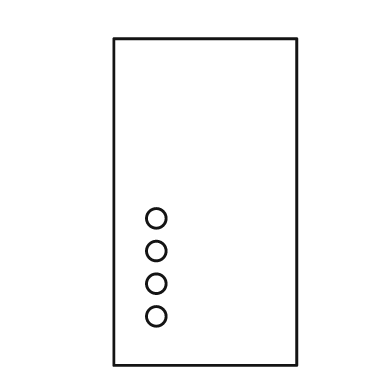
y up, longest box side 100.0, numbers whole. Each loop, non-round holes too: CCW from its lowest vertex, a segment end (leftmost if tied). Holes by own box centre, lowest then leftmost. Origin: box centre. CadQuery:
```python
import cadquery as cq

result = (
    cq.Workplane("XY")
    .moveTo(-28.0, -50.0)
    .lineTo(28.0, -50.0)
    .lineTo(28.0, 50.0)
    .lineTo(-28.0, 50.0)
    .close()
    .moveTo(-15.0, -35.0)
    .circle(3.0)
    .moveTo(-15.0, -25.0)
    .circle(3.0)
    .moveTo(-15.0, -15.0)
    .circle(3.0)
    .moveTo(-15.0, -5.0)
    .circle(3.0)
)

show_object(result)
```